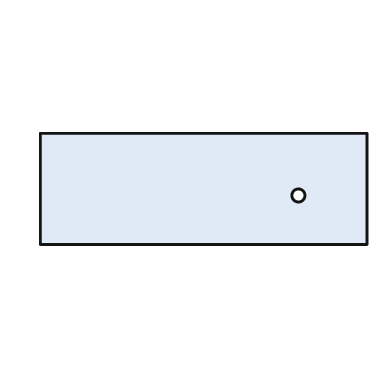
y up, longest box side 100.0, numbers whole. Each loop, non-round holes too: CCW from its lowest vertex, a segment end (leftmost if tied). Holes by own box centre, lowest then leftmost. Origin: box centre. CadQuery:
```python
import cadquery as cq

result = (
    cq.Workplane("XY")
    .moveTo(-50.0, -17.0)
    .lineTo(50.0, -17.0)
    .lineTo(50.0, 17.0)
    .lineTo(-50.0, 17.0)
    .close()
    .moveTo(29.0, -2.0)
    .circle(2.0)
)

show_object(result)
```